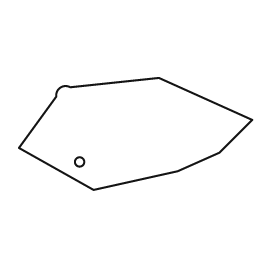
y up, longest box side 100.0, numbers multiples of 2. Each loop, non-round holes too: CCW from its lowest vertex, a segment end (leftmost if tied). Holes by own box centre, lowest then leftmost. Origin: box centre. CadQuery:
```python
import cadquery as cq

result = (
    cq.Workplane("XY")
    .moveTo(-18.0, -24.0)
    .lineTo(18.0, -16.0)
    .lineTo(36.0, -8.0)
    .lineTo(50.0, 6.0)
    .lineTo(10.0, 24.0)
    .lineTo(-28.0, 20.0)
    .threePointArc((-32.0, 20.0), (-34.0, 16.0))
    .lineTo(-50.0, -6.0)
    .close()
    .moveTo(-24.0, -12.0)
    .circle(2.0)
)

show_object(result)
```